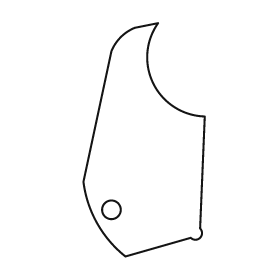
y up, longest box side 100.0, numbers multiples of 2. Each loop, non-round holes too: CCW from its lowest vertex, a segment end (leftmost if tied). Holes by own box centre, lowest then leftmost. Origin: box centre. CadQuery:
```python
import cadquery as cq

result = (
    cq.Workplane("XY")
    .moveTo(-8.0, -50.0)
    .lineTo(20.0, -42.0)
    .threePointArc((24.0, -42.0), (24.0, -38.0))
    .lineTo(26.0, 10.0)
    .threePointArc((4.0, 24.0), (6.0, 50.0))
    .lineTo(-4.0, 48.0)
    .threePointArc((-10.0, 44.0), (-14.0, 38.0))
    .lineTo(-26.0, -18.0)
    .threePointArc((-20.0, -36.0), (-8.0, -50.0))
    .close()
    .moveTo(-14.0, -30.0)
    .circle(4.0)
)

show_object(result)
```